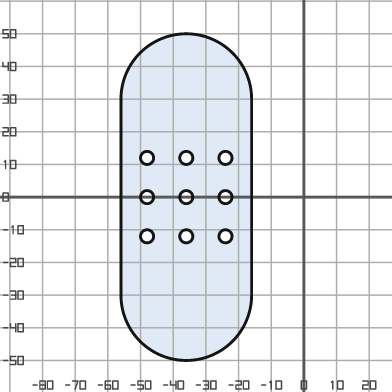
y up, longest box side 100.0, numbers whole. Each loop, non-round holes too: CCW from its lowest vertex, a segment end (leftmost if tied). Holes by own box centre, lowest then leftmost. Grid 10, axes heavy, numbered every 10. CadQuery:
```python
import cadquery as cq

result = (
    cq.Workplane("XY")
    .moveTo(-56.0, -30.0)
    .threePointArc((-36.0, -50.0), (-16.0, -30.0))
    .lineTo(-16.0, 30.0)
    .threePointArc((-36.0, 50.0), (-56.0, 30.0))
    .close()
    .moveTo(-48.0, -12.0)
    .circle(2.0)
    .moveTo(-36.0, -12.0)
    .circle(2.0)
    .moveTo(-24.0, -12.0)
    .circle(2.0)
    .moveTo(-48.0, 0.0)
    .circle(2.0)
    .moveTo(-36.0, 0.0)
    .circle(2.0)
    .moveTo(-24.0, 0.0)
    .circle(2.0)
    .moveTo(-48.0, 12.0)
    .circle(2.0)
    .moveTo(-36.0, 12.0)
    .circle(2.0)
    .moveTo(-24.0, 12.0)
    .circle(2.0)
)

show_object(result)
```